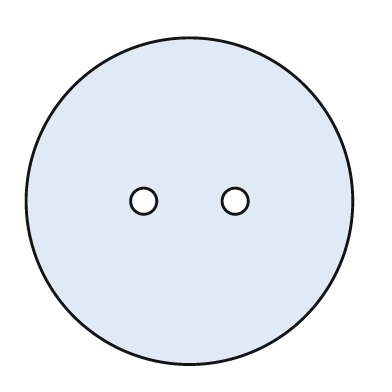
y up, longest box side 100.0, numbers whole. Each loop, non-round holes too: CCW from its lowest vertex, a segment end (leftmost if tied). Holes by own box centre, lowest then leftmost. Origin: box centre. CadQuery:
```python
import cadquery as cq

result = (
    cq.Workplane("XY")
    .moveTo(0.0, 0.0)
    .circle(50.0)
    .moveTo(-14.0, 0.0)
    .circle(4.0)
    .moveTo(14.0, 0.0)
    .circle(4.0)
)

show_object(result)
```